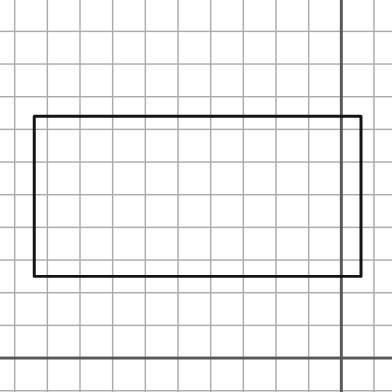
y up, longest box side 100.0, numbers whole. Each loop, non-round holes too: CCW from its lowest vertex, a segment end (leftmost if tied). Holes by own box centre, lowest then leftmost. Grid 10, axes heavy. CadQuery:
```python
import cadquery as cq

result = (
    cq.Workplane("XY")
    .moveTo(-94.0, 25.0)
    .lineTo(6.0, 25.0)
    .lineTo(6.0, 74.0)
    .lineTo(-94.0, 74.0)
    .close()
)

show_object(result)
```